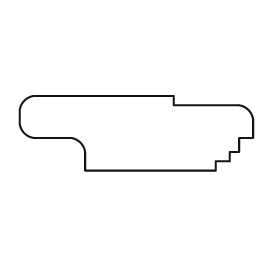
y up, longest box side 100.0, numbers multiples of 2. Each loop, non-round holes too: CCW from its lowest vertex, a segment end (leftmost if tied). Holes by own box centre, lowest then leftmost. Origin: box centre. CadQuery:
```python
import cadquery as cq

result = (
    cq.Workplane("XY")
    .moveTo(-22.0, -16.0)
    .lineTo(34.0, -16.0)
    .lineTo(34.0, -12.0)
    .lineTo(40.0, -12.0)
    .lineTo(40.0, -8.0)
    .lineTo(44.0, -8.0)
    .lineTo(44.0, -2.0)
    .lineTo(50.0, -2.0)
    .lineTo(50.0, 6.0)
    .threePointArc((48.0, 10.0), (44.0, 12.0))
    .lineTo(16.0, 12.0)
    .lineTo(16.0, 16.0)
    .lineTo(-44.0, 16.0)
    .threePointArc((-48.0, 14.0), (-50.0, 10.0))
    .lineTo(-50.0, 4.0)
    .threePointArc((-48.0, 0.0), (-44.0, -2.0))
    .lineTo(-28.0, -2.0)
    .threePointArc((-24.0, -4.0), (-22.0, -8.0))
    .close()
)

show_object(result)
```